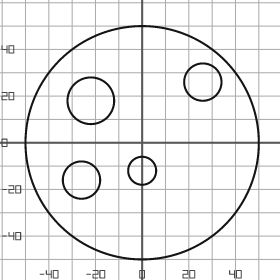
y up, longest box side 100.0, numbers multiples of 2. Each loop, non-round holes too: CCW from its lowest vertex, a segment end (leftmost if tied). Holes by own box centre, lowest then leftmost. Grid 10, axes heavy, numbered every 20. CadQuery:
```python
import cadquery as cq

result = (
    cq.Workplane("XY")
    .moveTo(0.0, 0.0)
    .circle(50.0)
    .moveTo(-26.0, -16.0)
    .circle(8.0)
    .moveTo(0.0, -12.0)
    .circle(6.0)
    .moveTo(-22.0, 18.0)
    .circle(10.0)
    .moveTo(26.0, 26.0)
    .circle(8.0)
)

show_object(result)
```